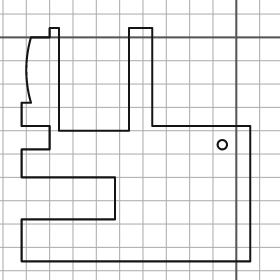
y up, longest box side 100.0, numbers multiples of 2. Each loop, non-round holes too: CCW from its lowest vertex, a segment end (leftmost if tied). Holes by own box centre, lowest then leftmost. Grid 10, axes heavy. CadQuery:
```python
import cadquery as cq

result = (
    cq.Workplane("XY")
    .moveTo(-92.0, -96.0)
    .lineTo(6.0, -96.0)
    .lineTo(6.0, -38.0)
    .lineTo(-36.0, -38.0)
    .lineTo(-36.0, 4.0)
    .lineTo(-46.0, 4.0)
    .lineTo(-46.0, -40.0)
    .lineTo(-76.0, -40.0)
    .lineTo(-76.0, 4.0)
    .lineTo(-80.0, 4.0)
    .lineTo(-80.0, 0.0)
    .lineTo(-88.0, 0.0)
    .threePointArc((-90.0, -14.0), (-88.0, -28.0))
    .lineTo(-92.0, -28.0)
    .lineTo(-92.0, -38.0)
    .lineTo(-80.0, -38.0)
    .lineTo(-80.0, -48.0)
    .lineTo(-92.0, -48.0)
    .lineTo(-92.0, -60.0)
    .lineTo(-52.0, -60.0)
    .lineTo(-52.0, -78.0)
    .lineTo(-92.0, -78.0)
    .close()
    .moveTo(-6.0, -46.0)
    .circle(2.0)
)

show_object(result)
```